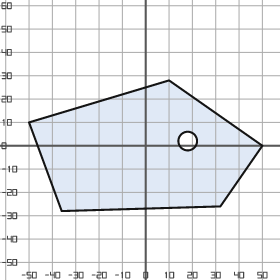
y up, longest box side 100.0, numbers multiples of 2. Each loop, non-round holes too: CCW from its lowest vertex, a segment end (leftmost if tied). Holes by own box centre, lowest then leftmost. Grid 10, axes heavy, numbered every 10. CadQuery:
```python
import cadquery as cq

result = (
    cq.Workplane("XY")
    .moveTo(-36.0, -28.0)
    .lineTo(32.0, -26.0)
    .lineTo(50.0, 0.0)
    .lineTo(10.0, 28.0)
    .lineTo(-50.0, 10.0)
    .close()
    .moveTo(18.0, 2.0)
    .circle(4.0)
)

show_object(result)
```